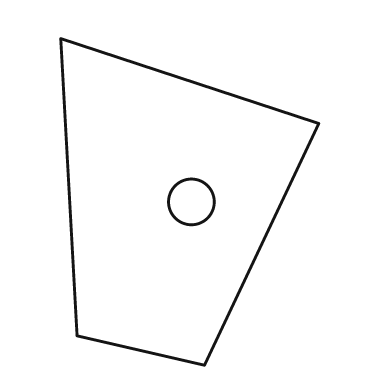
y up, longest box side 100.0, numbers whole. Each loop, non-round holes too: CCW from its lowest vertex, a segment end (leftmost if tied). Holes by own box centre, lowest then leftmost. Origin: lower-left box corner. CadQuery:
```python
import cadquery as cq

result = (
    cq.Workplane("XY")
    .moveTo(44.0, 0.0)
    .lineTo(79.0, 74.0)
    .lineTo(0.0, 100.0)
    .lineTo(5.0, 9.0)
    .close()
    .moveTo(40.0, 50.0)
    .circle(7.0)
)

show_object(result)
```